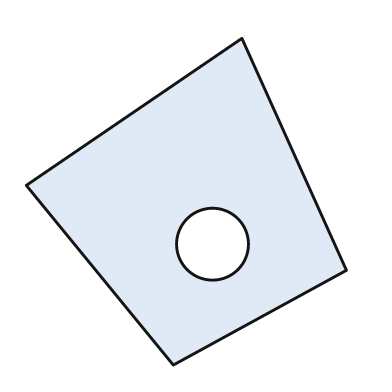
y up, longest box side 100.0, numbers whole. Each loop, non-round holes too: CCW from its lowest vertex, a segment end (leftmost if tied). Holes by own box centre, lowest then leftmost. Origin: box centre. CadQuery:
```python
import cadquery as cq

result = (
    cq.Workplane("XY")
    .moveTo(-4.0, -50.0)
    .lineTo(49.0, -21.0)
    .lineTo(17.0, 50.0)
    .lineTo(-49.0, 5.0)
    .close()
    .moveTo(8.0, -13.0)
    .circle(11.0)
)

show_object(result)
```